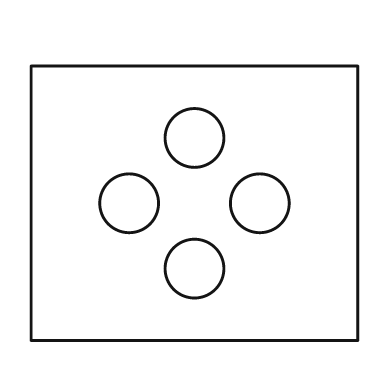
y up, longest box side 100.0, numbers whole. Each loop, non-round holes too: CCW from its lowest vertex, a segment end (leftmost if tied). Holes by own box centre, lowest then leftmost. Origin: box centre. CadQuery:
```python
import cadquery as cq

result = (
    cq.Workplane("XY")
    .moveTo(-50.0, -42.0)
    .lineTo(50.0, -42.0)
    .lineTo(50.0, 42.0)
    .lineTo(-50.0, 42.0)
    .close()
    .moveTo(0.0, -20.0)
    .circle(9.0)
    .moveTo(-20.0, 0.0)
    .circle(9.0)
    .moveTo(20.0, 0.0)
    .circle(9.0)
    .moveTo(0.0, 20.0)
    .circle(9.0)
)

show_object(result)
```